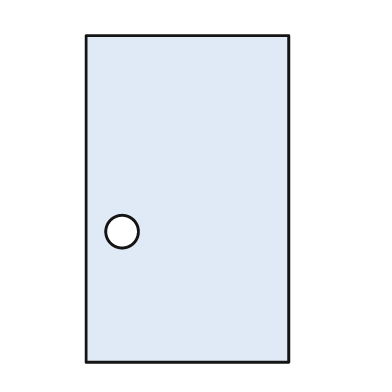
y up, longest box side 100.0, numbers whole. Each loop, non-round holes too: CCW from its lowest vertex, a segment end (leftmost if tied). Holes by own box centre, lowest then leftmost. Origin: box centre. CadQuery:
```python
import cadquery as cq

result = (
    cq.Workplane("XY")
    .moveTo(-31.0, -50.0)
    .lineTo(31.0, -50.0)
    .lineTo(31.0, 50.0)
    .lineTo(-31.0, 50.0)
    .close()
    .moveTo(-20.0, -10.0)
    .circle(5.0)
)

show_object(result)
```